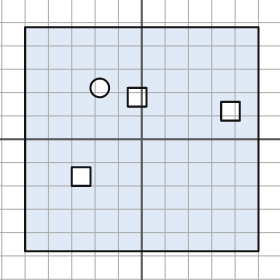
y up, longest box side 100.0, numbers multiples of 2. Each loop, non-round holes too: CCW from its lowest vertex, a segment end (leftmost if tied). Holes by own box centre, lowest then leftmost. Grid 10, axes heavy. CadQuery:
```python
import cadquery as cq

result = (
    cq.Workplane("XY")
    .moveTo(-50.0, -48.0)
    .lineTo(50.0, -48.0)
    .lineTo(50.0, 48.0)
    .lineTo(-50.0, 48.0)
    .close()
    .moveTo(-30.0, -20.0)
    .lineTo(-22.0, -20.0)
    .lineTo(-22.0, -12.0)
    .lineTo(-30.0, -12.0)
    .close()
    .moveTo(34.0, 8.0)
    .lineTo(42.0, 8.0)
    .lineTo(42.0, 16.0)
    .lineTo(34.0, 16.0)
    .close()
    .moveTo(-6.0, 14.0)
    .lineTo(2.0, 14.0)
    .lineTo(2.0, 22.0)
    .lineTo(-6.0, 22.0)
    .close()
    .moveTo(-18.0, 22.0)
    .circle(4.0)
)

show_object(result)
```